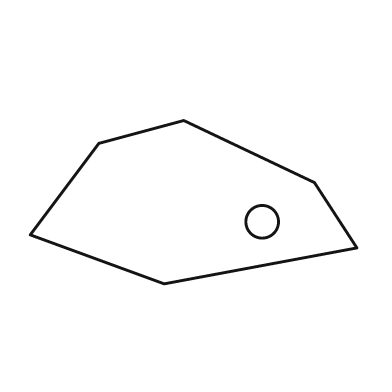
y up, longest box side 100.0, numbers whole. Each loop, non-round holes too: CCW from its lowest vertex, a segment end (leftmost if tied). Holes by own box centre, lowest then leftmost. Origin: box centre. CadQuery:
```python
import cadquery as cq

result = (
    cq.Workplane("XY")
    .moveTo(-9.0, -25.0)
    .lineTo(50.0, -14.0)
    .lineTo(37.0, 6.0)
    .lineTo(-3.0, 25.0)
    .lineTo(-29.0, 18.0)
    .lineTo(-50.0, -10.0)
    .close()
    .moveTo(21.0, -6.0)
    .circle(5.0)
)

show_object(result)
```